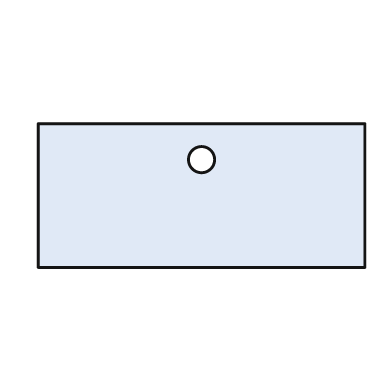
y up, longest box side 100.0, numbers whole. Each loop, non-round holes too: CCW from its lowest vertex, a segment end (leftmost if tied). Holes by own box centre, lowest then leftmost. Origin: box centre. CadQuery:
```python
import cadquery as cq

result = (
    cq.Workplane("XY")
    .moveTo(-50.0, -22.0)
    .lineTo(50.0, -22.0)
    .lineTo(50.0, 22.0)
    .lineTo(-50.0, 22.0)
    .close()
    .moveTo(0.0, 11.0)
    .circle(4.0)
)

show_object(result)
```